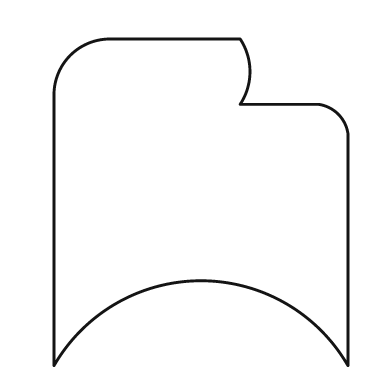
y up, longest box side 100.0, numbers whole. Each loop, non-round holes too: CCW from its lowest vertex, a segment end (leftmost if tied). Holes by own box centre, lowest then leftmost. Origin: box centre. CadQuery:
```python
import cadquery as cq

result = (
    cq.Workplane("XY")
    .moveTo(-45.0, -50.0)
    .threePointArc((0.0, -24.0), (45.0, -50.0))
    .lineTo(45.0, 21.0)
    .threePointArc((42.0, 27.0), (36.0, 30.0))
    .lineTo(12.0, 30.0)
    .threePointArc((15.0, 40.0), (12.0, 50.0))
    .lineTo(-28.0, 50.0)
    .threePointArc((-40.0, 45.0), (-45.0, 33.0))
    .close()
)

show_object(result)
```